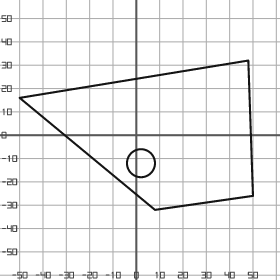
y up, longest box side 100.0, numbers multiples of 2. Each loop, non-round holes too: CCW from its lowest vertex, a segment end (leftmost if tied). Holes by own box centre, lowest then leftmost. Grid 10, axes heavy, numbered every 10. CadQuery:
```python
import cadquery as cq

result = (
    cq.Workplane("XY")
    .moveTo(8.0, -32.0)
    .lineTo(50.0, -26.0)
    .lineTo(48.0, 32.0)
    .lineTo(-50.0, 16.0)
    .close()
    .moveTo(2.0, -12.0)
    .circle(6.0)
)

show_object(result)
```